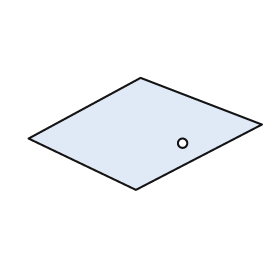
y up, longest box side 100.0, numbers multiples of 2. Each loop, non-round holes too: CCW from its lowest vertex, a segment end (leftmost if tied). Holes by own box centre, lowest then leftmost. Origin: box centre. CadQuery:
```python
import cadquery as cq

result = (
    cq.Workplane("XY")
    .moveTo(-4.0, -24.0)
    .lineTo(50.0, 4.0)
    .lineTo(-2.0, 24.0)
    .lineTo(-50.0, -2.0)
    .close()
    .moveTo(16.0, -4.0)
    .circle(2.0)
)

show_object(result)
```